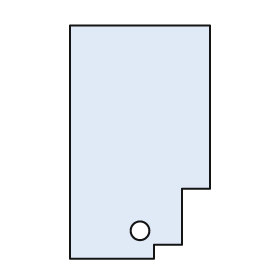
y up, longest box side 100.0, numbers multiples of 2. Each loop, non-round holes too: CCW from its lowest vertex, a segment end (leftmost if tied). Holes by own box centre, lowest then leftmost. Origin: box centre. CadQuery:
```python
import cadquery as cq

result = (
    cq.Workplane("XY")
    .moveTo(-30.0, -50.0)
    .lineTo(6.0, -50.0)
    .lineTo(6.0, -44.0)
    .lineTo(18.0, -44.0)
    .lineTo(18.0, -20.0)
    .lineTo(30.0, -20.0)
    .lineTo(30.0, 50.0)
    .lineTo(-30.0, 50.0)
    .close()
    .moveTo(0.0, -38.0)
    .circle(4.0)
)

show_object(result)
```